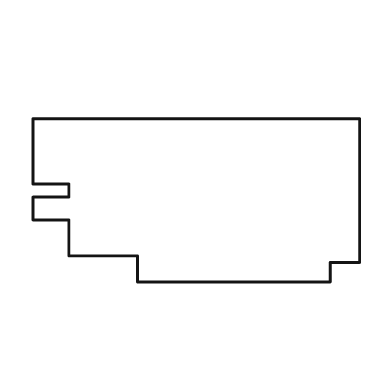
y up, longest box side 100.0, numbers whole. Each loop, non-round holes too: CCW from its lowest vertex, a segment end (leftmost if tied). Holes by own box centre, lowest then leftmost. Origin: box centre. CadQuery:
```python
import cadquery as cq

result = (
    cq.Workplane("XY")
    .moveTo(-18.0, -25.0)
    .lineTo(41.0, -25.0)
    .lineTo(41.0, -19.0)
    .lineTo(50.0, -19.0)
    .lineTo(50.0, 25.0)
    .lineTo(-50.0, 25.0)
    .lineTo(-50.0, 5.0)
    .lineTo(-39.0, 5.0)
    .lineTo(-39.0, 1.0)
    .lineTo(-50.0, 1.0)
    .lineTo(-50.0, -6.0)
    .lineTo(-39.0, -6.0)
    .lineTo(-39.0, -17.0)
    .lineTo(-18.0, -17.0)
    .close()
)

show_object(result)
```